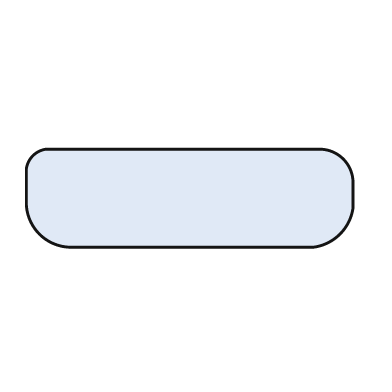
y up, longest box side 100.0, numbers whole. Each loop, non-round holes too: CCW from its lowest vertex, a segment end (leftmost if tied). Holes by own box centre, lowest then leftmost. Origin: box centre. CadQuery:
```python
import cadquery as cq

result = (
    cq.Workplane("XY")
    .moveTo(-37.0, -15.0)
    .lineTo(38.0, -15.0)
    .threePointArc((46.0, -11.0), (50.0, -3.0))
    .lineTo(50.0, 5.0)
    .threePointArc((47.0, 12.0), (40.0, 15.0))
    .lineTo(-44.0, 15.0)
    .threePointArc((-48.0, 13.0), (-50.0, 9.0))
    .lineTo(-50.0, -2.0)
    .threePointArc((-46.0, -11.0), (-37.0, -15.0))
    .close()
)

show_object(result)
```